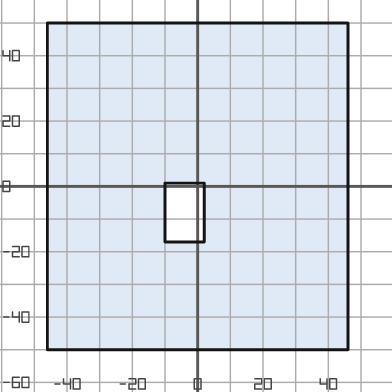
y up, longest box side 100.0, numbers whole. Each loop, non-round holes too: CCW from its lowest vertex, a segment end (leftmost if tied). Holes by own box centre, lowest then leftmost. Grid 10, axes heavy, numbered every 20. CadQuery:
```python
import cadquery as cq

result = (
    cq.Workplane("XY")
    .moveTo(-46.0, -50.0)
    .lineTo(46.0, -50.0)
    .lineTo(46.0, 50.0)
    .lineTo(-46.0, 50.0)
    .close()
    .moveTo(-10.0, -17.0)
    .lineTo(2.0, -17.0)
    .lineTo(2.0, 1.0)
    .lineTo(-10.0, 1.0)
    .close()
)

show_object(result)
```